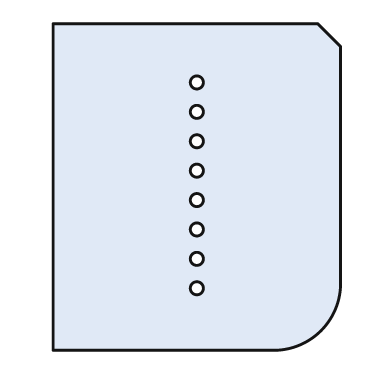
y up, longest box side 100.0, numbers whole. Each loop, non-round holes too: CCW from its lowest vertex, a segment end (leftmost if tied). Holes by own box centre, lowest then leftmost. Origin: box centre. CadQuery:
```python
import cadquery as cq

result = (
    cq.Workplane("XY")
    .moveTo(-44.0, -50.0)
    .lineTo(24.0, -50.0)
    .threePointArc((38.0, -44.0), (44.0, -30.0))
    .lineTo(44.0, 43.0)
    .lineTo(37.0, 50.0)
    .lineTo(-44.0, 50.0)
    .close()
    .moveTo(0.0, -31.0)
    .circle(2.0)
    .moveTo(0.0, -22.0)
    .circle(2.0)
    .moveTo(0.0, -13.0)
    .circle(2.0)
    .moveTo(0.0, -4.0)
    .circle(2.0)
    .moveTo(0.0, 5.0)
    .circle(2.0)
    .moveTo(0.0, 14.0)
    .circle(2.0)
    .moveTo(0.0, 23.0)
    .circle(2.0)
    .moveTo(0.0, 32.0)
    .circle(2.0)
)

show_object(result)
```